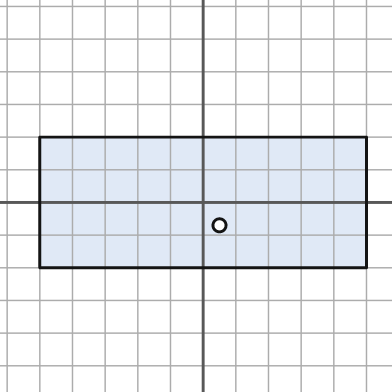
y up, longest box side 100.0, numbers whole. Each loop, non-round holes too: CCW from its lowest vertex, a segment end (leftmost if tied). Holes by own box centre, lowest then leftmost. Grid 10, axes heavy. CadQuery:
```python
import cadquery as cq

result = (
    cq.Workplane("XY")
    .moveTo(-50.0, -20.0)
    .lineTo(50.0, -20.0)
    .lineTo(50.0, 20.0)
    .lineTo(-50.0, 20.0)
    .close()
    .moveTo(5.0, -7.0)
    .circle(2.0)
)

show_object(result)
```